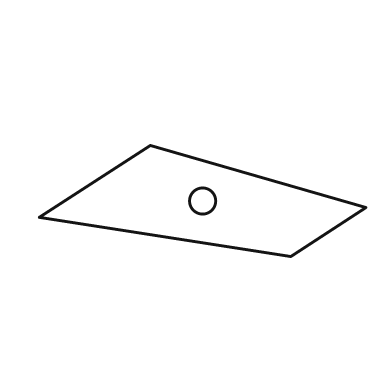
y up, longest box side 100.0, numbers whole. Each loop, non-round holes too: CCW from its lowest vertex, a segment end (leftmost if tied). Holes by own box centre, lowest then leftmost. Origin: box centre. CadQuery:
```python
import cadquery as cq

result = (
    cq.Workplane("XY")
    .moveTo(27.0, -17.0)
    .lineTo(50.0, -2.0)
    .lineTo(-16.0, 17.0)
    .lineTo(-50.0, -5.0)
    .close()
    .moveTo(0.0, 0.0)
    .circle(4.0)
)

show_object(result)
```